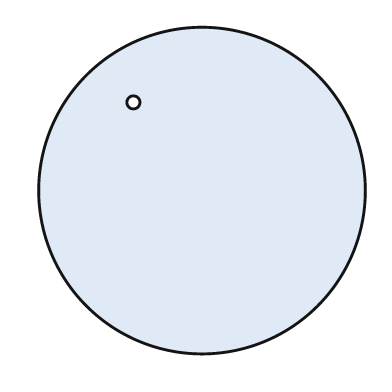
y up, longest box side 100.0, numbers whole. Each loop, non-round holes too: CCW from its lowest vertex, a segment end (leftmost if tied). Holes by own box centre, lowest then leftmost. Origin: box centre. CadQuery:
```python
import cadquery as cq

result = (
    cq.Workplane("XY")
    .moveTo(0.0, 0.0)
    .circle(50.0)
    .moveTo(-21.0, 27.0)
    .circle(2.0)
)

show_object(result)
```